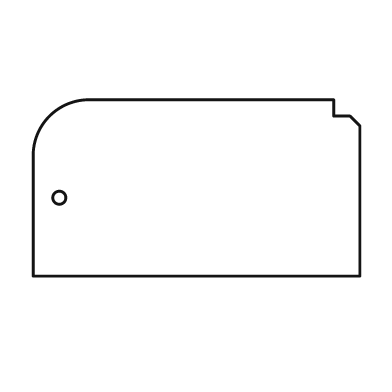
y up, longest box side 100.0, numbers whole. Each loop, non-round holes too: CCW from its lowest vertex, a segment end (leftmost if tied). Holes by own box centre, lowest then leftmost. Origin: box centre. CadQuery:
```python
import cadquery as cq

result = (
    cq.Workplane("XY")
    .moveTo(-50.0, -27.0)
    .lineTo(50.0, -27.0)
    .lineTo(50.0, 19.0)
    .lineTo(47.0, 22.0)
    .lineTo(42.0, 22.0)
    .lineTo(42.0, 27.0)
    .lineTo(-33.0, 27.0)
    .threePointArc((-45.0, 22.0), (-50.0, 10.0))
    .close()
    .moveTo(-42.0, -3.0)
    .circle(2.0)
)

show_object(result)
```